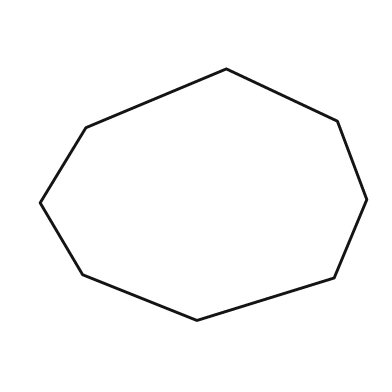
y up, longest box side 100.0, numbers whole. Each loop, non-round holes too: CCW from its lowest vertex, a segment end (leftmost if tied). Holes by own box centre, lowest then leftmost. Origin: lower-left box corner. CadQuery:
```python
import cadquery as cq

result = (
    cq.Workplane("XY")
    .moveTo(48.0, 0.0)
    .lineTo(90.0, 13.0)
    .lineTo(100.0, 37.0)
    .lineTo(91.0, 61.0)
    .lineTo(57.0, 77.0)
    .lineTo(14.0, 59.0)
    .lineTo(0.0, 36.0)
    .lineTo(13.0, 14.0)
    .close()
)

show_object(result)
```